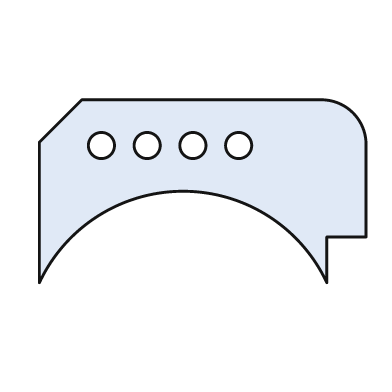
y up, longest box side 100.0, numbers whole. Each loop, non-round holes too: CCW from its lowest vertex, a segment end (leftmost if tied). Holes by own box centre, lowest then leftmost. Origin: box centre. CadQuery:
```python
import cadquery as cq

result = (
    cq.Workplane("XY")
    .moveTo(-50.0, -28.0)
    .threePointArc((-6.0, 0.0), (38.0, -28.0))
    .lineTo(38.0, -14.0)
    .lineTo(50.0, -14.0)
    .lineTo(50.0, 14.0)
    .threePointArc((46.0, 24.0), (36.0, 28.0))
    .lineTo(-37.0, 28.0)
    .lineTo(-50.0, 15.0)
    .close()
    .moveTo(-31.0, 14.0)
    .circle(4.0)
    .moveTo(-17.0, 14.0)
    .circle(4.0)
    .moveTo(-3.0, 14.0)
    .circle(4.0)
    .moveTo(11.0, 14.0)
    .circle(4.0)
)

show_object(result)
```